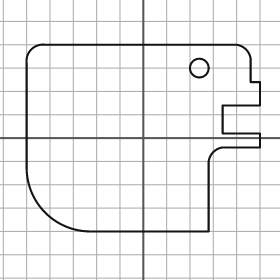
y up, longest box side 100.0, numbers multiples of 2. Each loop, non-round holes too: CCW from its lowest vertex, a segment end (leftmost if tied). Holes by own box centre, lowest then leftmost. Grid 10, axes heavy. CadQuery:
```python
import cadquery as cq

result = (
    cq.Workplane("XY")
    .moveTo(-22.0, -40.0)
    .lineTo(28.0, -40.0)
    .lineTo(28.0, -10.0)
    .threePointArc((30.0, -6.0), (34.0, -4.0))
    .lineTo(50.0, -4.0)
    .lineTo(50.0, 2.0)
    .lineTo(34.0, 2.0)
    .lineTo(34.0, 14.0)
    .lineTo(50.0, 14.0)
    .lineTo(50.0, 24.0)
    .lineTo(46.0, 24.0)
    .lineTo(46.0, 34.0)
    .threePointArc((44.0, 38.0), (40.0, 40.0))
    .lineTo(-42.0, 40.0)
    .threePointArc((-48.0, 38.0), (-50.0, 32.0))
    .lineTo(-50.0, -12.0)
    .threePointArc((-42.0, -32.0), (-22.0, -40.0))
    .close()
    .moveTo(24.0, 30.0)
    .circle(4.0)
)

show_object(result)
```